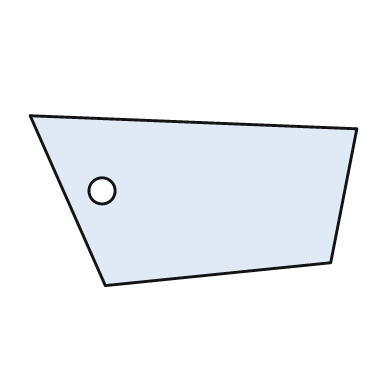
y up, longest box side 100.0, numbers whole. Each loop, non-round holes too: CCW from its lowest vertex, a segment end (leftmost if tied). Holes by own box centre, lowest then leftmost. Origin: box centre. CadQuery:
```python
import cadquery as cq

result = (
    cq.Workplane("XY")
    .moveTo(-27.0, -26.0)
    .lineTo(42.0, -19.0)
    .lineTo(50.0, 22.0)
    .lineTo(-50.0, 26.0)
    .close()
    .moveTo(-28.0, 3.0)
    .circle(4.0)
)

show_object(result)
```